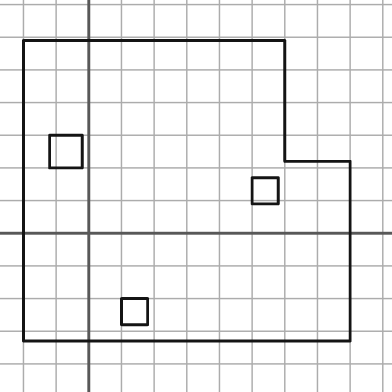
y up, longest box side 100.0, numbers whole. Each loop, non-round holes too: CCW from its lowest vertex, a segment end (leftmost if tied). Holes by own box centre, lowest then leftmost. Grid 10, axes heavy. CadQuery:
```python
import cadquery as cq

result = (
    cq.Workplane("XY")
    .moveTo(-20.0, -33.0)
    .lineTo(80.0, -33.0)
    .lineTo(80.0, 22.0)
    .lineTo(60.0, 22.0)
    .lineTo(60.0, 59.0)
    .lineTo(-20.0, 59.0)
    .close()
    .moveTo(10.0, -28.0)
    .lineTo(18.0, -28.0)
    .lineTo(18.0, -20.0)
    .lineTo(10.0, -20.0)
    .close()
    .moveTo(50.0, 9.0)
    .lineTo(58.0, 9.0)
    .lineTo(58.0, 17.0)
    .lineTo(50.0, 17.0)
    .close()
    .moveTo(-12.0, 20.0)
    .lineTo(-2.0, 20.0)
    .lineTo(-2.0, 30.0)
    .lineTo(-12.0, 30.0)
    .close()
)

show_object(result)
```